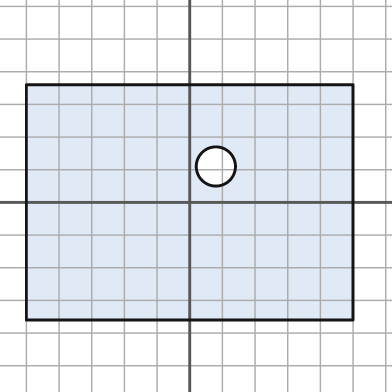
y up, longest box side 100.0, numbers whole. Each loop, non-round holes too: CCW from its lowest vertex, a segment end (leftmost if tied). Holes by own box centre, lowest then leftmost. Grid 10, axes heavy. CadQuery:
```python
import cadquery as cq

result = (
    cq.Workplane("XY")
    .moveTo(-50.0, -36.0)
    .lineTo(50.0, -36.0)
    .lineTo(50.0, 36.0)
    .lineTo(-50.0, 36.0)
    .close()
    .moveTo(8.0, 11.0)
    .circle(6.0)
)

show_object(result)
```